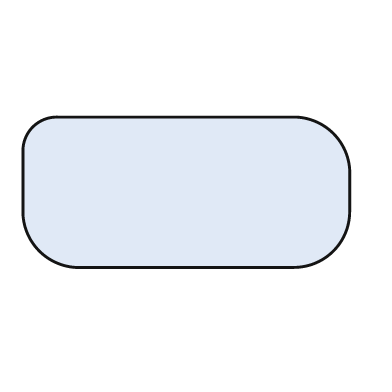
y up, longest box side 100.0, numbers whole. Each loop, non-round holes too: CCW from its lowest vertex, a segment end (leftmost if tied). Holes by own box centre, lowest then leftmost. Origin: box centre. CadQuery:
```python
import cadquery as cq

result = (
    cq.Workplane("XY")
    .moveTo(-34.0, -23.0)
    .lineTo(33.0, -23.0)
    .threePointArc((45.0, -18.0), (50.0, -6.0))
    .lineTo(50.0, 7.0)
    .threePointArc((45.0, 18.0), (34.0, 23.0))
    .lineTo(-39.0, 23.0)
    .threePointArc((-47.0, 20.0), (-50.0, 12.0))
    .lineTo(-50.0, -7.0)
    .threePointArc((-45.0, -18.0), (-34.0, -23.0))
    .close()
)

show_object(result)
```